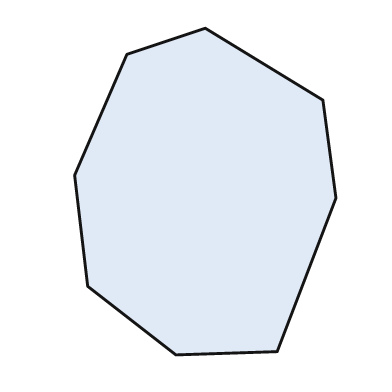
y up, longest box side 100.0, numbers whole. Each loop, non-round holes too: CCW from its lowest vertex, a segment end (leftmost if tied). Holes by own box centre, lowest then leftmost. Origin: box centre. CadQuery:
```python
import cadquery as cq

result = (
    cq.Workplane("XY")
    .moveTo(-9.0, -50.0)
    .lineTo(22.0, -49.0)
    .lineTo(40.0, -2.0)
    .lineTo(36.0, 28.0)
    .lineTo(0.0, 50.0)
    .lineTo(-24.0, 42.0)
    .lineTo(-40.0, 5.0)
    .lineTo(-36.0, -29.0)
    .close()
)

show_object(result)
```